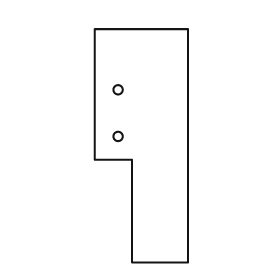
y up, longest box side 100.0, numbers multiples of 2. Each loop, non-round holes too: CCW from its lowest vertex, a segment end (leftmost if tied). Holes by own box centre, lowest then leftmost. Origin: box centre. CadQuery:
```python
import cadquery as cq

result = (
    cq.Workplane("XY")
    .moveTo(-4.0, -50.0)
    .lineTo(20.0, -50.0)
    .lineTo(20.0, 50.0)
    .lineTo(-20.0, 50.0)
    .lineTo(-20.0, -6.0)
    .lineTo(-4.0, -6.0)
    .close()
    .moveTo(-10.0, 4.0)
    .circle(2.0)
    .moveTo(-10.0, 24.0)
    .circle(2.0)
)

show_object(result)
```